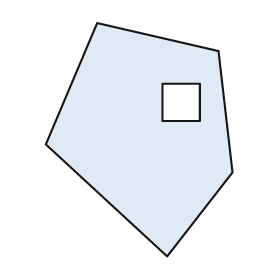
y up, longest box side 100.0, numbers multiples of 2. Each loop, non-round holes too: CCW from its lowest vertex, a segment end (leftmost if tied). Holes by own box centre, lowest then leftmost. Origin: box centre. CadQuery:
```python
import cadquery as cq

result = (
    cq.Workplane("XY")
    .moveTo(12.0, -50.0)
    .lineTo(40.0, -14.0)
    .lineTo(34.0, 38.0)
    .lineTo(-18.0, 50.0)
    .lineTo(-40.0, -2.0)
    .close()
    .moveTo(10.0, 8.0)
    .lineTo(26.0, 8.0)
    .lineTo(26.0, 24.0)
    .lineTo(10.0, 24.0)
    .close()
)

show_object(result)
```